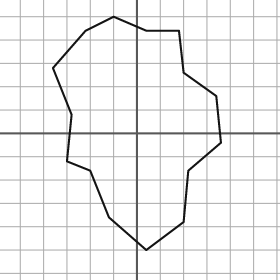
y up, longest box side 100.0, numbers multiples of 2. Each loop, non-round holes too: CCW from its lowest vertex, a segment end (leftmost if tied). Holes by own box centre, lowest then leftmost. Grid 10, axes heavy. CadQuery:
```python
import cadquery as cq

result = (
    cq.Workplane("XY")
    .moveTo(4.0, -50.0)
    .lineTo(20.0, -38.0)
    .lineTo(22.0, -16.0)
    .lineTo(36.0, -4.0)
    .lineTo(34.0, 16.0)
    .lineTo(20.0, 26.0)
    .lineTo(18.0, 44.0)
    .lineTo(4.0, 44.0)
    .lineTo(-10.0, 50.0)
    .lineTo(-22.0, 44.0)
    .lineTo(-36.0, 28.0)
    .lineTo(-28.0, 8.0)
    .lineTo(-30.0, -12.0)
    .lineTo(-20.0, -16.0)
    .lineTo(-12.0, -36.0)
    .close()
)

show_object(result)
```